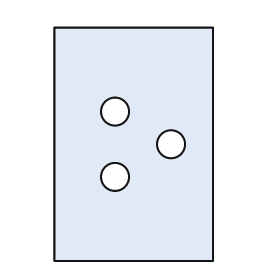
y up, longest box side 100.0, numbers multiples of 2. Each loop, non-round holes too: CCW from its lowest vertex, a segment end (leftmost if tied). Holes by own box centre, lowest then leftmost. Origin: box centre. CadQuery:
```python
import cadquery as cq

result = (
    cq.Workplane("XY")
    .moveTo(-34.0, -50.0)
    .lineTo(34.0, -50.0)
    .lineTo(34.0, 50.0)
    .lineTo(-34.0, 50.0)
    .close()
    .moveTo(-8.0, -14.0)
    .circle(6.0)
    .moveTo(16.0, 0.0)
    .circle(6.0)
    .moveTo(-8.0, 14.0)
    .circle(6.0)
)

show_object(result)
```